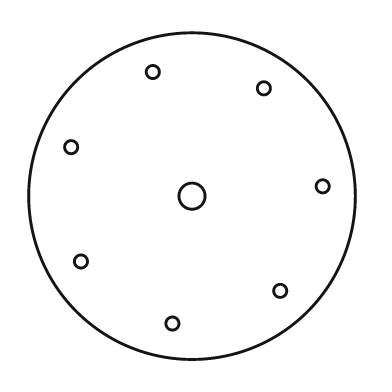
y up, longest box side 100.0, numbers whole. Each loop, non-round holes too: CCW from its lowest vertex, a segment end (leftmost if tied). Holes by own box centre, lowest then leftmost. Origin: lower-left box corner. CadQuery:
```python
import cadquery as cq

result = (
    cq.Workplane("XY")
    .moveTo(50.0, 50.0)
    .circle(50.0)
    .moveTo(44.0, 11.0)
    .circle(2.0)
    .moveTo(77.0, 21.0)
    .circle(2.0)
    .moveTo(16.0, 30.0)
    .circle(2.0)
    .moveTo(50.0, 50.0)
    .circle(4.0)
    .moveTo(90.0, 53.0)
    .circle(2.0)
    .moveTo(13.0, 65.0)
    .circle(2.0)
    .moveTo(72.0, 83.0)
    .circle(2.0)
    .moveTo(38.0, 88.0)
    .circle(2.0)
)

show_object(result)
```